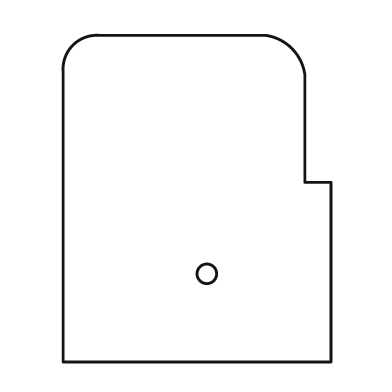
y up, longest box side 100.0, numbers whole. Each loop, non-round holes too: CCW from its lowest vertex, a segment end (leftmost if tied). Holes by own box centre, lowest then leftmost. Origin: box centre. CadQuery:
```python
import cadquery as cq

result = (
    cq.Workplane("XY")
    .moveTo(-41.0, -50.0)
    .lineTo(41.0, -50.0)
    .lineTo(41.0, 5.0)
    .lineTo(33.0, 5.0)
    .lineTo(33.0, 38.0)
    .threePointArc((29.0, 46.0), (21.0, 50.0))
    .lineTo(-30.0, 50.0)
    .threePointArc((-38.0, 47.0), (-41.0, 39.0))
    .close()
    .moveTo(3.0, -23.0)
    .circle(3.0)
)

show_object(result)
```